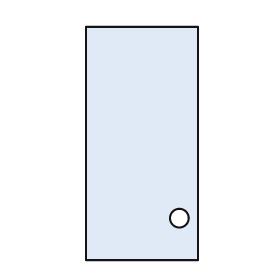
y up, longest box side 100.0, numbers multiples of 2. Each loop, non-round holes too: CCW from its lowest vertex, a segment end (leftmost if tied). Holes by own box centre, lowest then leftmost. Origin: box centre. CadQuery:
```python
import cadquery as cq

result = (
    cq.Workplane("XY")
    .moveTo(-24.0, -50.0)
    .lineTo(24.0, -50.0)
    .lineTo(24.0, 50.0)
    .lineTo(-24.0, 50.0)
    .close()
    .moveTo(16.0, -32.0)
    .circle(4.0)
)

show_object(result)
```